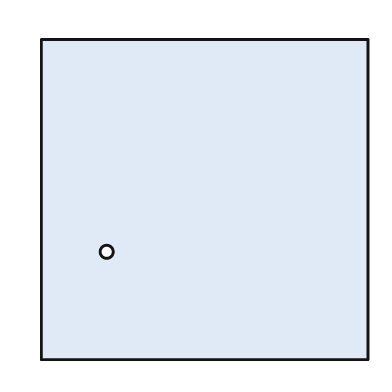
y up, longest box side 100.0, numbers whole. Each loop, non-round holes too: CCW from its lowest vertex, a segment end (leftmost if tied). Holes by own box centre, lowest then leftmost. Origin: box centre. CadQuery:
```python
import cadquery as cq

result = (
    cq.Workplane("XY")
    .moveTo(-50.0, -49.0)
    .lineTo(50.0, -49.0)
    .lineTo(50.0, 49.0)
    .lineTo(-50.0, 49.0)
    .close()
    .moveTo(-30.0, -16.0)
    .circle(2.0)
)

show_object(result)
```